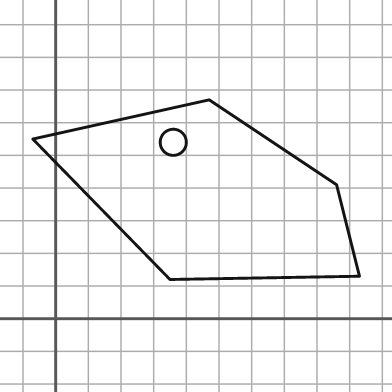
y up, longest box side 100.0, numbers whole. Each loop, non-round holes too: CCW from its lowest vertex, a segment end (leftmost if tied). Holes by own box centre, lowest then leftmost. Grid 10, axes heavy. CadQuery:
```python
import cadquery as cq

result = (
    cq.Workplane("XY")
    .moveTo(35.0, 12.0)
    .lineTo(93.0, 13.0)
    .lineTo(86.0, 41.0)
    .lineTo(47.0, 67.0)
    .lineTo(-7.0, 55.0)
    .close()
    .moveTo(36.0, 54.0)
    .circle(4.0)
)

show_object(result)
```